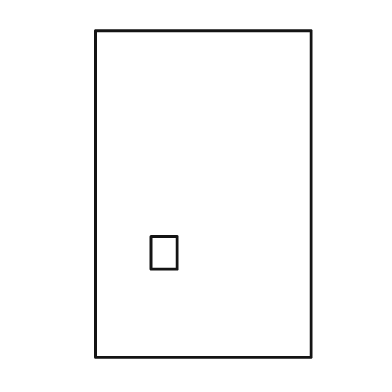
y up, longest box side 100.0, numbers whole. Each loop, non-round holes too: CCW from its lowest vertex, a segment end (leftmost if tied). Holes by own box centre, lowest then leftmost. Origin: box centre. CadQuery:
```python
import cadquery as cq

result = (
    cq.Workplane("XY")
    .moveTo(-33.0, -50.0)
    .lineTo(33.0, -50.0)
    .lineTo(33.0, 50.0)
    .lineTo(-33.0, 50.0)
    .close()
    .moveTo(-16.0, -23.0)
    .lineTo(-8.0, -23.0)
    .lineTo(-8.0, -13.0)
    .lineTo(-16.0, -13.0)
    .close()
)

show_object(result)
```